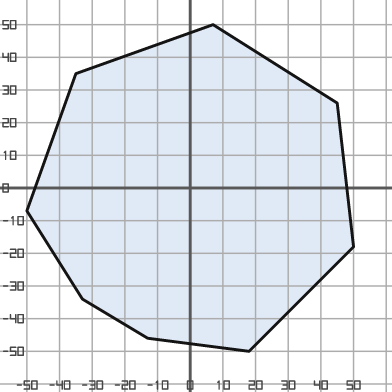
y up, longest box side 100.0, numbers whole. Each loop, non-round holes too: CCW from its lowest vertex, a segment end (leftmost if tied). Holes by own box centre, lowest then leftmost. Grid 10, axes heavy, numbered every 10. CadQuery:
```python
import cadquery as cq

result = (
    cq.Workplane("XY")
    .moveTo(18.0, -50.0)
    .lineTo(50.0, -18.0)
    .lineTo(45.0, 26.0)
    .lineTo(7.0, 50.0)
    .lineTo(-35.0, 35.0)
    .lineTo(-50.0, -7.0)
    .lineTo(-33.0, -34.0)
    .lineTo(-13.0, -46.0)
    .close()
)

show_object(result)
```